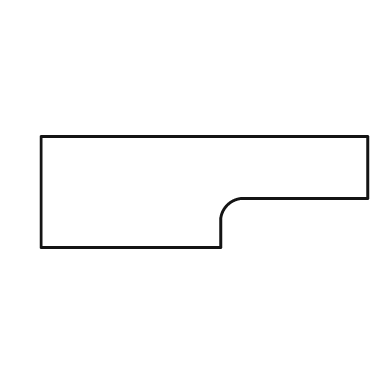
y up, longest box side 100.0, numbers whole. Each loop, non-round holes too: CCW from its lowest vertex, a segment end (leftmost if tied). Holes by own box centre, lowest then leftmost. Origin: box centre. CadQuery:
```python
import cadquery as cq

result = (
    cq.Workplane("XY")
    .moveTo(-50.0, -17.0)
    .lineTo(5.0, -17.0)
    .lineTo(5.0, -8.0)
    .threePointArc((7.0, -4.0), (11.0, -2.0))
    .lineTo(50.0, -2.0)
    .lineTo(50.0, 17.0)
    .lineTo(-50.0, 17.0)
    .close()
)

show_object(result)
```